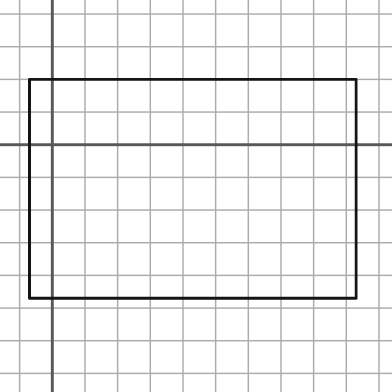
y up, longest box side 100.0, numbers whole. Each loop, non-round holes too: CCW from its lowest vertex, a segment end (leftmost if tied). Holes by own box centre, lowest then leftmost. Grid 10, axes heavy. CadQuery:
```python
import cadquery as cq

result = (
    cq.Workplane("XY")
    .moveTo(-7.0, -47.0)
    .lineTo(93.0, -47.0)
    .lineTo(93.0, 20.0)
    .lineTo(-7.0, 20.0)
    .close()
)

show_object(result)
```